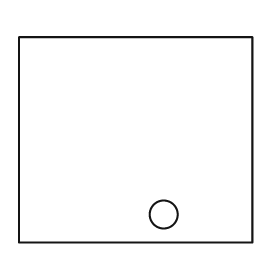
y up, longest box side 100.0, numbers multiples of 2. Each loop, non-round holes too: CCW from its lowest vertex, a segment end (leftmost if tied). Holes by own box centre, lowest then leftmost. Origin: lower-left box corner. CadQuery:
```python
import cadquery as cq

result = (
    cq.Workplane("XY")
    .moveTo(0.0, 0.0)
    .lineTo(100.0, 0.0)
    .lineTo(100.0, 88.0)
    .lineTo(0.0, 88.0)
    .close()
    .moveTo(62.0, 12.0)
    .circle(6.0)
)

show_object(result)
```